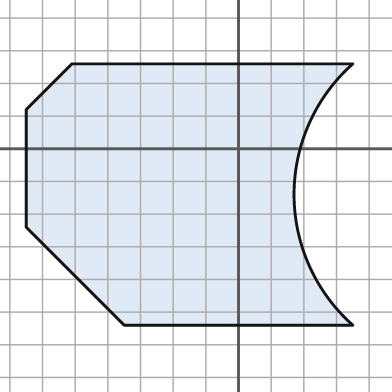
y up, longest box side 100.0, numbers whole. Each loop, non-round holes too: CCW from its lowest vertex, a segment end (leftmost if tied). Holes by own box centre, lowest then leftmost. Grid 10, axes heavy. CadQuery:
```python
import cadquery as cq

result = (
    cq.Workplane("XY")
    .moveTo(-35.0, -54.0)
    .lineTo(35.0, -54.0)
    .threePointArc((17.0, -14.0), (35.0, 26.0))
    .lineTo(-51.0, 26.0)
    .lineTo(-65.0, 12.0)
    .lineTo(-65.0, -24.0)
    .close()
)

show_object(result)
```